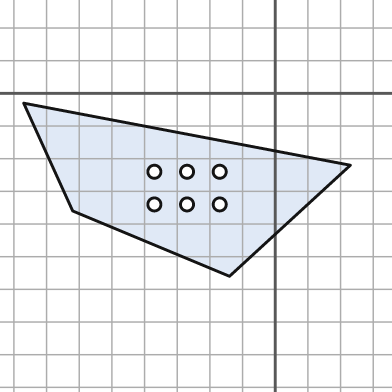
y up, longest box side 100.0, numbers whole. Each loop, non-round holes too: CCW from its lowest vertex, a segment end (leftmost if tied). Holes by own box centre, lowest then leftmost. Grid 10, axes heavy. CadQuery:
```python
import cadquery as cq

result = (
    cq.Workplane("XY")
    .moveTo(-14.0, -56.0)
    .lineTo(23.0, -22.0)
    .lineTo(-77.0, -3.0)
    .lineTo(-62.0, -36.0)
    .close()
    .moveTo(-37.0, -34.0)
    .circle(2.0)
    .moveTo(-27.0, -34.0)
    .circle(2.0)
    .moveTo(-17.0, -34.0)
    .circle(2.0)
    .moveTo(-37.0, -24.0)
    .circle(2.0)
    .moveTo(-27.0, -24.0)
    .circle(2.0)
    .moveTo(-17.0, -24.0)
    .circle(2.0)
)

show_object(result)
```